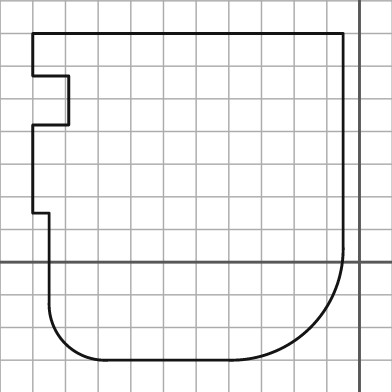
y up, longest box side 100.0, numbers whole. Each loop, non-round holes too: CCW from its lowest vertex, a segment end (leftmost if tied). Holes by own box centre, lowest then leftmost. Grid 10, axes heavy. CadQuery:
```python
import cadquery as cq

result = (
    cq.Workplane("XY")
    .moveTo(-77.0, -30.0)
    .lineTo(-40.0, -30.0)
    .threePointArc((-15.0, -20.0), (-5.0, 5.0))
    .lineTo(-5.0, 70.0)
    .lineTo(-100.0, 70.0)
    .lineTo(-100.0, 57.0)
    .lineTo(-89.0, 57.0)
    .lineTo(-89.0, 42.0)
    .lineTo(-100.0, 42.0)
    .lineTo(-100.0, 15.0)
    .lineTo(-95.0, 15.0)
    .lineTo(-95.0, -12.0)
    .threePointArc((-90.0, -25.0), (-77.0, -30.0))
    .close()
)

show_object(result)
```